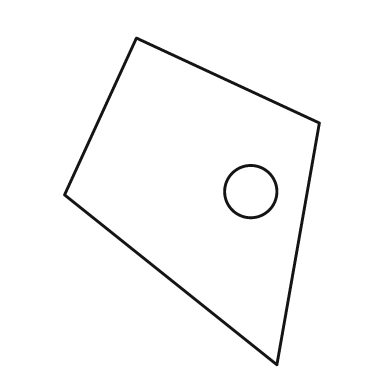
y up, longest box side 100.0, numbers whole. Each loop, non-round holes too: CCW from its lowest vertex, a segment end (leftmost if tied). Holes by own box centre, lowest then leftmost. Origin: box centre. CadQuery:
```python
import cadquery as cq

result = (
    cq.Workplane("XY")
    .moveTo(26.0, -50.0)
    .lineTo(39.0, 24.0)
    .lineTo(-17.0, 50.0)
    .lineTo(-39.0, 2.0)
    .close()
    .moveTo(18.0, 3.0)
    .circle(8.0)
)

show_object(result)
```